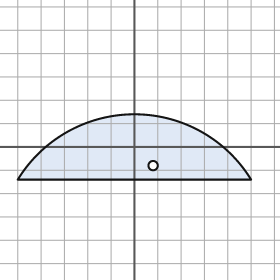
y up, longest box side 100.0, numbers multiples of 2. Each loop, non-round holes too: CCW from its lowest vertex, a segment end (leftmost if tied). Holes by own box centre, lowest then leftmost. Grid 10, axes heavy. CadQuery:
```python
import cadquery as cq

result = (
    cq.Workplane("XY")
    .moveTo(-50.0, -14.0)
    .lineTo(50.0, -14.0)
    .threePointArc((0.0, 14.0), (-50.0, -14.0))
    .close()
    .moveTo(8.0, -8.0)
    .circle(2.0)
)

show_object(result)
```